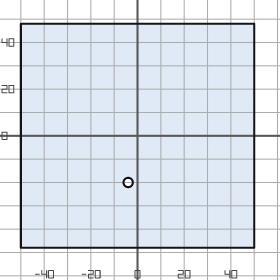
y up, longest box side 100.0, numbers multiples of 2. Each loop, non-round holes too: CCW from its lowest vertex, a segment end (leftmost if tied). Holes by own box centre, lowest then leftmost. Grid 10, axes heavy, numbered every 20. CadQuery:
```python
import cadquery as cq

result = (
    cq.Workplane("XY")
    .moveTo(-50.0, -48.0)
    .lineTo(50.0, -48.0)
    .lineTo(50.0, 48.0)
    .lineTo(-50.0, 48.0)
    .close()
    .moveTo(-4.0, -20.0)
    .circle(2.0)
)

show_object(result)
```